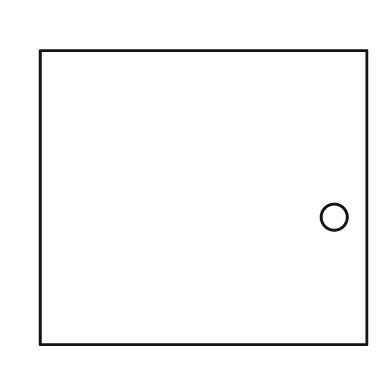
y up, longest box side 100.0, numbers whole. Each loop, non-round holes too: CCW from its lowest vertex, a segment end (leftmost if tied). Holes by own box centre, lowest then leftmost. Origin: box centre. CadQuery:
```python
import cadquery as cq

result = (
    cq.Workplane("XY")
    .moveTo(-50.0, -45.0)
    .lineTo(50.0, -45.0)
    .lineTo(50.0, 45.0)
    .lineTo(-50.0, 45.0)
    .close()
    .moveTo(40.0, -6.0)
    .circle(4.0)
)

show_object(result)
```